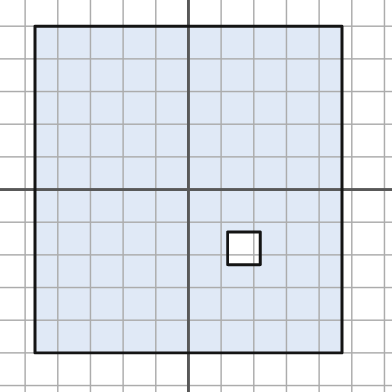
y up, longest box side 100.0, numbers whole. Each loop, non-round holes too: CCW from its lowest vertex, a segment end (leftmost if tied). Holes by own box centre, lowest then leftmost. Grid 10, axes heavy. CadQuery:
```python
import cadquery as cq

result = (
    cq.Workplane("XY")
    .moveTo(-47.0, -50.0)
    .lineTo(47.0, -50.0)
    .lineTo(47.0, 50.0)
    .lineTo(-47.0, 50.0)
    .close()
    .moveTo(12.0, -23.0)
    .lineTo(22.0, -23.0)
    .lineTo(22.0, -13.0)
    .lineTo(12.0, -13.0)
    .close()
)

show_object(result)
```